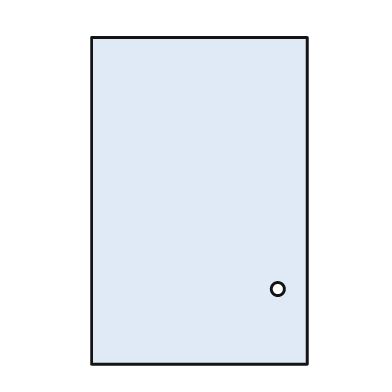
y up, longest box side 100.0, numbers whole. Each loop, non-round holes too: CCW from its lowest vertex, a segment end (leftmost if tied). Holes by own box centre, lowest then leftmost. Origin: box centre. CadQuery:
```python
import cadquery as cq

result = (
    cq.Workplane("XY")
    .moveTo(-33.0, -50.0)
    .lineTo(33.0, -50.0)
    .lineTo(33.0, 50.0)
    .lineTo(-33.0, 50.0)
    .close()
    .moveTo(24.0, -27.0)
    .circle(2.0)
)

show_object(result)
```